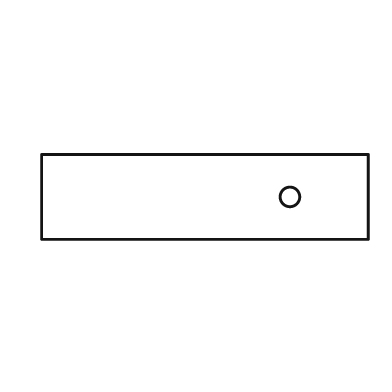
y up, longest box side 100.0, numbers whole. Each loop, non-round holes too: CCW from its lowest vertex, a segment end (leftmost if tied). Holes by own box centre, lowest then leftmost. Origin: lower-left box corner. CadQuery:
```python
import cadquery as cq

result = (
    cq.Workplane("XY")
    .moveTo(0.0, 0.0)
    .lineTo(100.0, 0.0)
    .lineTo(100.0, 26.0)
    .lineTo(0.0, 26.0)
    .close()
    .moveTo(76.0, 13.0)
    .circle(3.0)
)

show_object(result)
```